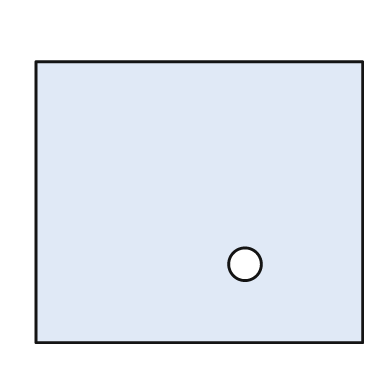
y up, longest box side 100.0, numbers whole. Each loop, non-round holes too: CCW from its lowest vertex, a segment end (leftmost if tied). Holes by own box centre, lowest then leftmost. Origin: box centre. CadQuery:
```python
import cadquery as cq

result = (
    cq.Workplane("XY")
    .moveTo(-50.0, -43.0)
    .lineTo(50.0, -43.0)
    .lineTo(50.0, 43.0)
    .lineTo(-50.0, 43.0)
    .close()
    .moveTo(14.0, -19.0)
    .circle(5.0)
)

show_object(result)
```